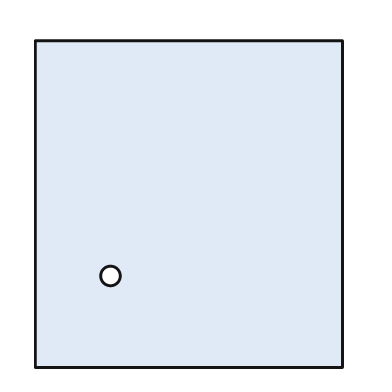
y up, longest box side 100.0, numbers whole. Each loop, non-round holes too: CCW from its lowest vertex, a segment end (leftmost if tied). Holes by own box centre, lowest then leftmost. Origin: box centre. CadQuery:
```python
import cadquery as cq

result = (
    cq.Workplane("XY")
    .moveTo(-47.0, -50.0)
    .lineTo(47.0, -50.0)
    .lineTo(47.0, 50.0)
    .lineTo(-47.0, 50.0)
    .close()
    .moveTo(-24.0, -22.0)
    .circle(3.0)
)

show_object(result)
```